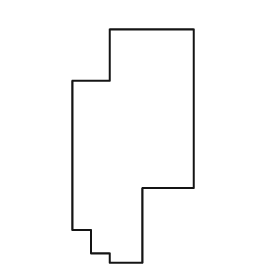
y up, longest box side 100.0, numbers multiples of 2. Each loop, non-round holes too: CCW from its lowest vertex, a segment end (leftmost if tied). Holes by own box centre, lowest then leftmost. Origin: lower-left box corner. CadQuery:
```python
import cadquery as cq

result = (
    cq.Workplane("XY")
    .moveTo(16.0, 0.0)
    .lineTo(30.0, 0.0)
    .lineTo(30.0, 32.0)
    .lineTo(52.0, 32.0)
    .lineTo(52.0, 100.0)
    .lineTo(16.0, 100.0)
    .lineTo(16.0, 78.0)
    .lineTo(0.0, 78.0)
    .lineTo(0.0, 14.0)
    .lineTo(8.0, 14.0)
    .lineTo(8.0, 4.0)
    .lineTo(16.0, 4.0)
    .close()
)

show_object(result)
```